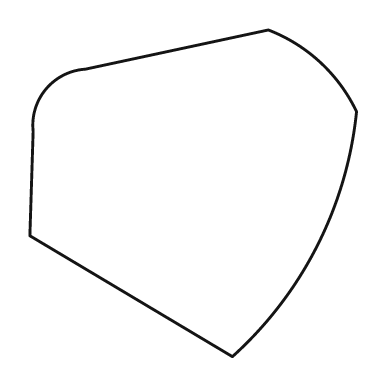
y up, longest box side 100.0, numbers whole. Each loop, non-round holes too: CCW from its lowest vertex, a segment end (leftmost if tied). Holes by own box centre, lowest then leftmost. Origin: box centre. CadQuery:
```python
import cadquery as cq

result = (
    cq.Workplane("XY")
    .moveTo(12.0, -50.0)
    .threePointArc((38.0, -16.0), (50.0, 25.0))
    .threePointArc((39.0, 40.0), (23.0, 50.0))
    .lineTo(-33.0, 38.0)
    .threePointArc((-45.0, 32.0), (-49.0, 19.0))
    .lineTo(-50.0, -13.0)
    .close()
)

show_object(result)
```